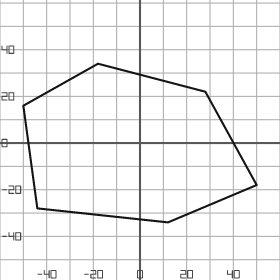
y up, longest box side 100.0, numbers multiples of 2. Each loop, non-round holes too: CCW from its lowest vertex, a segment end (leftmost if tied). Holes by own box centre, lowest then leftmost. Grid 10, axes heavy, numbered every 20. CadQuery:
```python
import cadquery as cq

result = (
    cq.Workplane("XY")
    .moveTo(12.0, -34.0)
    .lineTo(50.0, -18.0)
    .lineTo(28.0, 22.0)
    .lineTo(-18.0, 34.0)
    .lineTo(-50.0, 16.0)
    .lineTo(-44.0, -28.0)
    .close()
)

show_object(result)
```